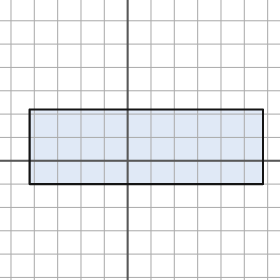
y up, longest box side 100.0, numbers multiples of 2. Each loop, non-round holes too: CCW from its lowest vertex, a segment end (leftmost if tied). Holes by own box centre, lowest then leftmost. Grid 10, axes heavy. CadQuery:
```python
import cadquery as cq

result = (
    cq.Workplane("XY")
    .moveTo(-42.0, -10.0)
    .lineTo(58.0, -10.0)
    .lineTo(58.0, 22.0)
    .lineTo(-42.0, 22.0)
    .close()
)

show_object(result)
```